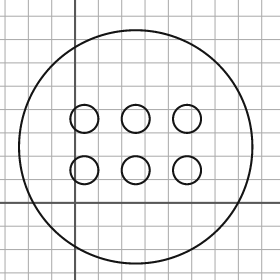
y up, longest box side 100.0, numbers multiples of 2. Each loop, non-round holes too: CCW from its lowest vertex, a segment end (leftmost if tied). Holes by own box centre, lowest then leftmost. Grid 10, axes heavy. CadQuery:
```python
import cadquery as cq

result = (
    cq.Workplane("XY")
    .moveTo(26.0, 24.0)
    .circle(50.0)
    .moveTo(4.0, 14.0)
    .circle(6.0)
    .moveTo(26.0, 14.0)
    .circle(6.0)
    .moveTo(48.0, 14.0)
    .circle(6.0)
    .moveTo(4.0, 36.0)
    .circle(6.0)
    .moveTo(26.0, 36.0)
    .circle(6.0)
    .moveTo(48.0, 36.0)
    .circle(6.0)
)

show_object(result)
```